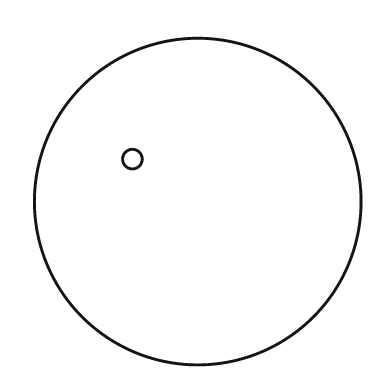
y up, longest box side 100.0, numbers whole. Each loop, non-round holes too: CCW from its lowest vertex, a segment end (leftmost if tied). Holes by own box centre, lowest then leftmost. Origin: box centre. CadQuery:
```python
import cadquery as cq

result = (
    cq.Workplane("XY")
    .moveTo(0.0, 0.0)
    .circle(50.0)
    .moveTo(-20.0, 13.0)
    .circle(3.0)
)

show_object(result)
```